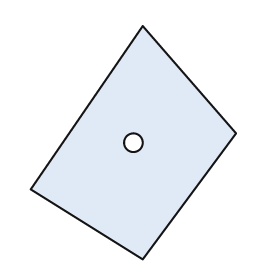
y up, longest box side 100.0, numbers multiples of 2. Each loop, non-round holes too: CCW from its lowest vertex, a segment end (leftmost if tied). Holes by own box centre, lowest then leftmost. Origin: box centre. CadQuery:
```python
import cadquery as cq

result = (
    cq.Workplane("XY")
    .moveTo(4.0, -50.0)
    .lineTo(44.0, 4.0)
    .lineTo(4.0, 50.0)
    .lineTo(-44.0, -20.0)
    .close()
    .moveTo(0.0, 0.0)
    .circle(4.0)
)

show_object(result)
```